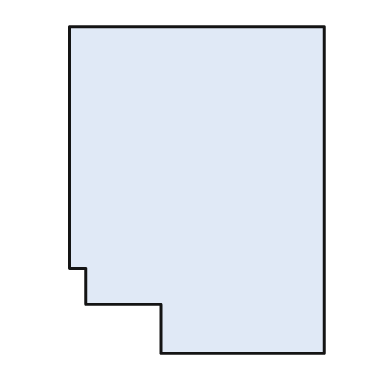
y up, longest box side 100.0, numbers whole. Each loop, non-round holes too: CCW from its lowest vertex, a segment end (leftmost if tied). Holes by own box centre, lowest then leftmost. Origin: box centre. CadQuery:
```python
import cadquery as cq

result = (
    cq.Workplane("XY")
    .moveTo(-11.0, -50.0)
    .lineTo(39.0, -50.0)
    .lineTo(39.0, 50.0)
    .lineTo(-39.0, 50.0)
    .lineTo(-39.0, -24.0)
    .lineTo(-34.0, -24.0)
    .lineTo(-34.0, -35.0)
    .lineTo(-11.0, -35.0)
    .close()
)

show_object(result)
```